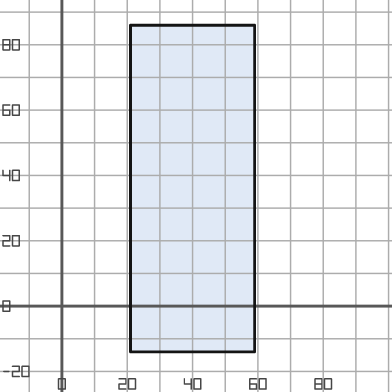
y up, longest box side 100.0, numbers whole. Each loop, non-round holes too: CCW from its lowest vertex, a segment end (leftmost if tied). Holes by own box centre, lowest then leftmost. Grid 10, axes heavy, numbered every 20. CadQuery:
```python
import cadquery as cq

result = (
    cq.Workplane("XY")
    .moveTo(21.0, -14.0)
    .lineTo(59.0, -14.0)
    .lineTo(59.0, 86.0)
    .lineTo(21.0, 86.0)
    .close()
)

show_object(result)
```